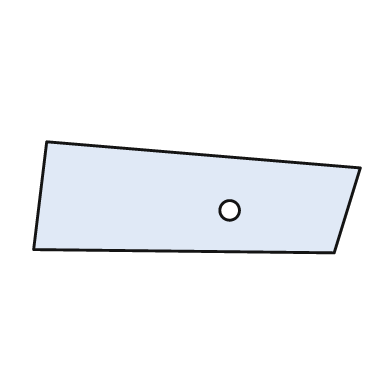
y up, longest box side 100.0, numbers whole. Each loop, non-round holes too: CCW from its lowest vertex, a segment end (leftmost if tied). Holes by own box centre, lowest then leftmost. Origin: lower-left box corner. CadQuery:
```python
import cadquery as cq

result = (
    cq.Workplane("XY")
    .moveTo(92.0, 0.0)
    .lineTo(100.0, 26.0)
    .lineTo(4.0, 34.0)
    .lineTo(0.0, 1.0)
    .close()
    .moveTo(60.0, 13.0)
    .circle(3.0)
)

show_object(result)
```